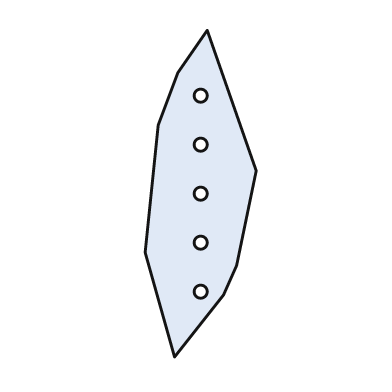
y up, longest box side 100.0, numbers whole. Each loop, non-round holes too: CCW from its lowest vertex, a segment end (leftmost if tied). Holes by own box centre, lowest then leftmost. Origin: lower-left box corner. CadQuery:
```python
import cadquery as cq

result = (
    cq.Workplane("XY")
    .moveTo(9.0, 0.0)
    .lineTo(24.0, 19.0)
    .lineTo(28.0, 28.0)
    .lineTo(34.0, 57.0)
    .lineTo(19.0, 100.0)
    .lineTo(10.0, 87.0)
    .lineTo(4.0, 71.0)
    .lineTo(0.0, 32.0)
    .close()
    .moveTo(17.0, 20.0)
    .circle(2.0)
    .moveTo(17.0, 35.0)
    .circle(2.0)
    .moveTo(17.0, 50.0)
    .circle(2.0)
    .moveTo(17.0, 65.0)
    .circle(2.0)
    .moveTo(17.0, 80.0)
    .circle(2.0)
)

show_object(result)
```